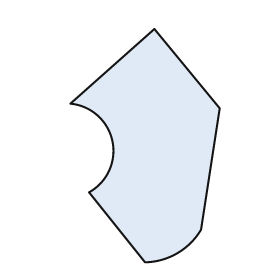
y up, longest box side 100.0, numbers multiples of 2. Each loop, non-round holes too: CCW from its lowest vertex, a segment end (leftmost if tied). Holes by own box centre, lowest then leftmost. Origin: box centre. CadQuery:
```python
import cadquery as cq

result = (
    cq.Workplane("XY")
    .moveTo(0.0, -50.0)
    .threePointArc((14.0, -46.0), (24.0, -36.0))
    .lineTo(32.0, 16.0)
    .lineTo(4.0, 50.0)
    .lineTo(-32.0, 18.0)
    .threePointArc((-14.0, 2.0), (-24.0, -20.0))
    .close()
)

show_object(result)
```